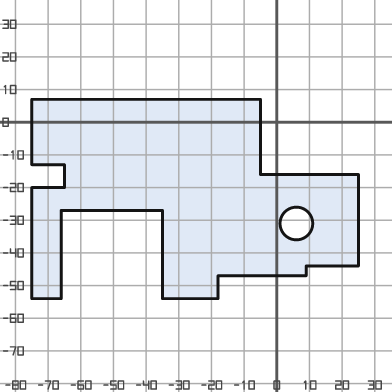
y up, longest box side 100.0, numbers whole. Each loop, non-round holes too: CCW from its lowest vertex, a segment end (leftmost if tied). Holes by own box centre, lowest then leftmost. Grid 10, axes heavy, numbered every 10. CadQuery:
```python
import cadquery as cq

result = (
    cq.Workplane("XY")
    .moveTo(-75.0, -54.0)
    .lineTo(-66.0, -54.0)
    .lineTo(-66.0, -27.0)
    .lineTo(-35.0, -27.0)
    .lineTo(-35.0, -54.0)
    .lineTo(-18.0, -54.0)
    .lineTo(-18.0, -47.0)
    .lineTo(9.0, -47.0)
    .lineTo(9.0, -44.0)
    .lineTo(25.0, -44.0)
    .lineTo(25.0, -16.0)
    .lineTo(-5.0, -16.0)
    .lineTo(-5.0, 7.0)
    .lineTo(-75.0, 7.0)
    .lineTo(-75.0, -13.0)
    .lineTo(-65.0, -13.0)
    .lineTo(-65.0, -20.0)
    .lineTo(-75.0, -20.0)
    .close()
    .moveTo(6.0, -31.0)
    .circle(5.0)
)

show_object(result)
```